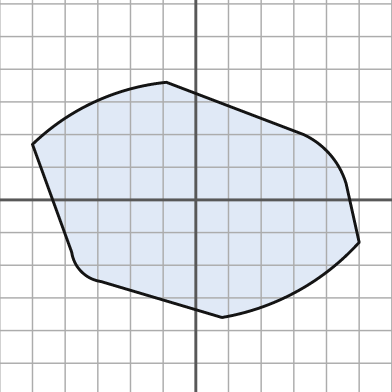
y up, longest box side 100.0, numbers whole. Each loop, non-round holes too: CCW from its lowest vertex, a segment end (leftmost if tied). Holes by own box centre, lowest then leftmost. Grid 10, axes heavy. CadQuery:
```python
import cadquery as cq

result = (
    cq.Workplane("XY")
    .moveTo(8.0, -36.0)
    .threePointArc((31.0, -28.0), (50.0, -13.0))
    .lineTo(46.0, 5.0)
    .threePointArc((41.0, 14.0), (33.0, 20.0))
    .lineTo(-9.0, 36.0)
    .threePointArc((-31.0, 30.0), (-50.0, 17.0))
    .lineTo(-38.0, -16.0)
    .threePointArc((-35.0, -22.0), (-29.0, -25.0))
    .close()
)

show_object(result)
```